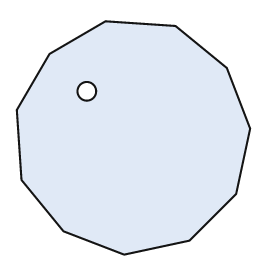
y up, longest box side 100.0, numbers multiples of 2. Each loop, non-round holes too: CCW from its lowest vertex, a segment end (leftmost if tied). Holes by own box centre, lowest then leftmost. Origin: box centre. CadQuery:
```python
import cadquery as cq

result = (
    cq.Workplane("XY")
    .moveTo(-4.0, -50.0)
    .lineTo(24.0, -44.0)
    .lineTo(44.0, -24.0)
    .lineTo(50.0, 4.0)
    .lineTo(40.0, 30.0)
    .lineTo(18.0, 48.0)
    .lineTo(-12.0, 50.0)
    .lineTo(-36.0, 36.0)
    .lineTo(-50.0, 12.0)
    .lineTo(-48.0, -18.0)
    .lineTo(-30.0, -40.0)
    .close()
    .moveTo(-20.0, 20.0)
    .circle(4.0)
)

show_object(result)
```